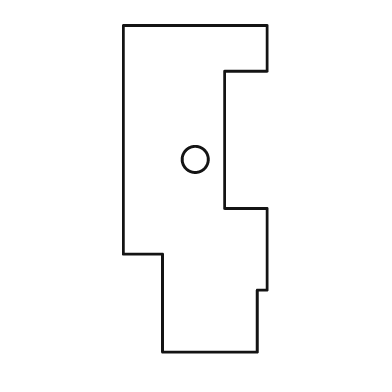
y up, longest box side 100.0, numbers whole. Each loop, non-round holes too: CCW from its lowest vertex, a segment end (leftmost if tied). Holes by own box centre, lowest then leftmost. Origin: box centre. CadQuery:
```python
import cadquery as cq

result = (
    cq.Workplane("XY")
    .moveTo(-10.0, -50.0)
    .lineTo(19.0, -50.0)
    .lineTo(19.0, -31.0)
    .lineTo(22.0, -31.0)
    .lineTo(22.0, -6.0)
    .lineTo(9.0, -6.0)
    .lineTo(9.0, 36.0)
    .lineTo(22.0, 36.0)
    .lineTo(22.0, 50.0)
    .lineTo(-22.0, 50.0)
    .lineTo(-22.0, -20.0)
    .lineTo(-10.0, -20.0)
    .close()
    .moveTo(0.0, 9.0)
    .circle(4.0)
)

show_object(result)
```